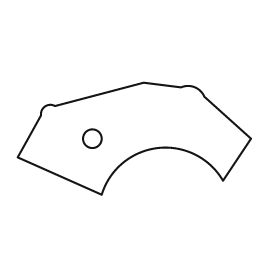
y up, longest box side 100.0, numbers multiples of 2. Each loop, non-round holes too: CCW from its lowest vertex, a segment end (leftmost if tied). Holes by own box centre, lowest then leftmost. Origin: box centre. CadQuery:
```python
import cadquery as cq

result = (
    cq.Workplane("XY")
    .moveTo(-14.0, -24.0)
    .threePointArc((10.0, -4.0), (38.0, -18.0))
    .lineTo(50.0, 0.0)
    .lineTo(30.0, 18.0)
    .threePointArc((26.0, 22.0), (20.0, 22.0))
    .lineTo(4.0, 24.0)
    .lineTo(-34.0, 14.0)
    .threePointArc((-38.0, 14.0), (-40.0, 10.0))
    .lineTo(-50.0, -8.0)
    .close()
    .moveTo(-18.0, 0.0)
    .circle(4.0)
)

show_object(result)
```